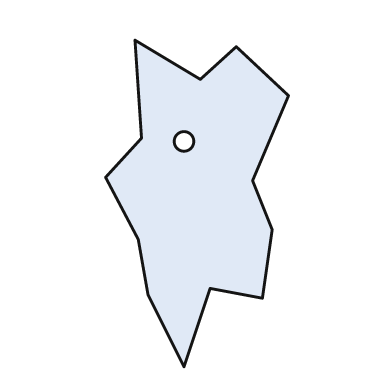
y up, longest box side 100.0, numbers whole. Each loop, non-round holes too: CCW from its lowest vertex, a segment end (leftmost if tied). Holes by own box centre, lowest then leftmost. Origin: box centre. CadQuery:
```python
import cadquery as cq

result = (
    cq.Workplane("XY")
    .moveTo(-4.0, -50.0)
    .lineTo(4.0, -26.0)
    .lineTo(20.0, -29.0)
    .lineTo(23.0, -8.0)
    .lineTo(17.0, 7.0)
    .lineTo(28.0, 33.0)
    .lineTo(12.0, 48.0)
    .lineTo(1.0, 38.0)
    .lineTo(-19.0, 50.0)
    .lineTo(-17.0, 20.0)
    .lineTo(-28.0, 8.0)
    .lineTo(-18.0, -11.0)
    .lineTo(-15.0, -28.0)
    .close()
    .moveTo(-4.0, 19.0)
    .circle(3.0)
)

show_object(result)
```